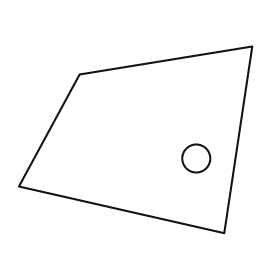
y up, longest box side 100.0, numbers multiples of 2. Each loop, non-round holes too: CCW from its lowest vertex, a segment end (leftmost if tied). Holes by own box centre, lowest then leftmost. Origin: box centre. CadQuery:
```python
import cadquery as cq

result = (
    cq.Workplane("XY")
    .moveTo(38.0, -40.0)
    .lineTo(50.0, 40.0)
    .lineTo(-24.0, 28.0)
    .lineTo(-50.0, -20.0)
    .close()
    .moveTo(26.0, -8.0)
    .circle(6.0)
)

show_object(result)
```